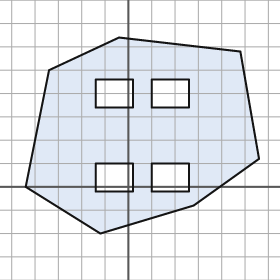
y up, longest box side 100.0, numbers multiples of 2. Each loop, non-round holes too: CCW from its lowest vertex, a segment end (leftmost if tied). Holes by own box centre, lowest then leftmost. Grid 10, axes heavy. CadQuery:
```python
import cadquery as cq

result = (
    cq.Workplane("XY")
    .moveTo(-12.0, -20.0)
    .lineTo(28.0, -8.0)
    .lineTo(56.0, 12.0)
    .lineTo(48.0, 58.0)
    .lineTo(-4.0, 64.0)
    .lineTo(-34.0, 50.0)
    .lineTo(-44.0, 0.0)
    .close()
    .moveTo(-14.0, -2.0)
    .lineTo(2.0, -2.0)
    .lineTo(2.0, 10.0)
    .lineTo(-14.0, 10.0)
    .close()
    .moveTo(10.0, -2.0)
    .lineTo(26.0, -2.0)
    .lineTo(26.0, 10.0)
    .lineTo(10.0, 10.0)
    .close()
    .moveTo(-14.0, 34.0)
    .lineTo(2.0, 34.0)
    .lineTo(2.0, 46.0)
    .lineTo(-14.0, 46.0)
    .close()
    .moveTo(10.0, 34.0)
    .lineTo(26.0, 34.0)
    .lineTo(26.0, 46.0)
    .lineTo(10.0, 46.0)
    .close()
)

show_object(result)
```